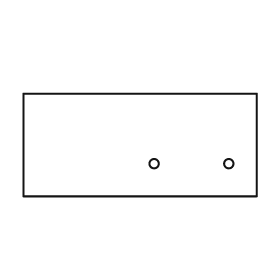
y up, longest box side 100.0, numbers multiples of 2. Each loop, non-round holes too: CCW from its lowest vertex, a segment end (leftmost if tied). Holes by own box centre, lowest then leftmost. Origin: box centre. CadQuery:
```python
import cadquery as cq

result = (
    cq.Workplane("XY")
    .moveTo(-50.0, -22.0)
    .lineTo(50.0, -22.0)
    .lineTo(50.0, 22.0)
    .lineTo(-50.0, 22.0)
    .close()
    .moveTo(6.0, -8.0)
    .circle(2.0)
    .moveTo(38.0, -8.0)
    .circle(2.0)
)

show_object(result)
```